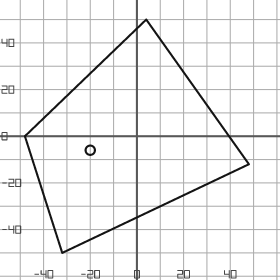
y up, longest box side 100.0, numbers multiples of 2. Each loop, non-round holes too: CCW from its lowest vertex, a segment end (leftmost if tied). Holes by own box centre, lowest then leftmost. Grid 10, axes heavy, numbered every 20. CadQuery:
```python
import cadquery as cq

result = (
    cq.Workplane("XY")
    .moveTo(-32.0, -50.0)
    .lineTo(48.0, -12.0)
    .lineTo(4.0, 50.0)
    .lineTo(-48.0, 0.0)
    .close()
    .moveTo(-20.0, -6.0)
    .circle(2.0)
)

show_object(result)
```